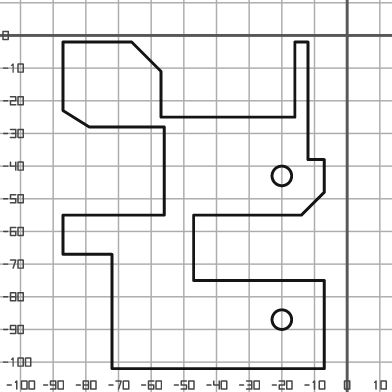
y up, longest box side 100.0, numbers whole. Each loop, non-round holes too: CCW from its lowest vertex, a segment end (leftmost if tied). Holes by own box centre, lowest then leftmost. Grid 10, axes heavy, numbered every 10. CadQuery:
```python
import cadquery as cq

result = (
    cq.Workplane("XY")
    .moveTo(-72.0, -102.0)
    .lineTo(-7.0, -102.0)
    .lineTo(-7.0, -75.0)
    .lineTo(-47.0, -75.0)
    .lineTo(-47.0, -55.0)
    .lineTo(-14.0, -55.0)
    .lineTo(-7.0, -48.0)
    .lineTo(-7.0, -38.0)
    .lineTo(-12.0, -38.0)
    .lineTo(-12.0, -2.0)
    .lineTo(-16.0, -2.0)
    .lineTo(-16.0, -25.0)
    .lineTo(-57.0, -25.0)
    .lineTo(-57.0, -11.0)
    .lineTo(-66.0, -2.0)
    .lineTo(-87.0, -2.0)
    .lineTo(-87.0, -23.0)
    .lineTo(-79.0, -28.0)
    .lineTo(-56.0, -28.0)
    .lineTo(-56.0, -55.0)
    .lineTo(-87.0, -55.0)
    .lineTo(-87.0, -67.0)
    .lineTo(-72.0, -67.0)
    .close()
    .moveTo(-20.0, -87.0)
    .circle(3.0)
    .moveTo(-20.0, -43.0)
    .circle(3.0)
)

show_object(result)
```